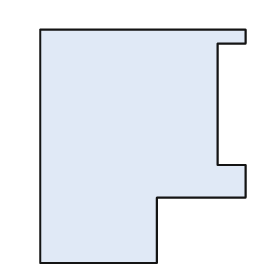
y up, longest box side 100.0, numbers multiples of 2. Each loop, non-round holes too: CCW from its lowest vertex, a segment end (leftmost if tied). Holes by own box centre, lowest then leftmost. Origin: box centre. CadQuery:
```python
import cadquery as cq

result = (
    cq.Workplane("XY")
    .moveTo(-44.0, -50.0)
    .lineTo(6.0, -50.0)
    .lineTo(6.0, -22.0)
    .lineTo(44.0, -22.0)
    .lineTo(44.0, -8.0)
    .lineTo(32.0, -8.0)
    .lineTo(32.0, 44.0)
    .lineTo(44.0, 44.0)
    .lineTo(44.0, 50.0)
    .lineTo(-44.0, 50.0)
    .close()
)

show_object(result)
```